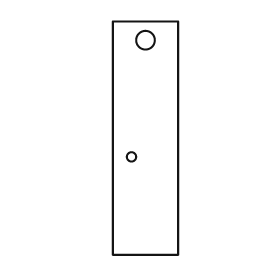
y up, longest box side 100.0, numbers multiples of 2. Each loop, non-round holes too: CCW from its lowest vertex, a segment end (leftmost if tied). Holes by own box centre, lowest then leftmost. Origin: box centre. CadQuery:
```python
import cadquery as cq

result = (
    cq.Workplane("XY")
    .moveTo(-14.0, -50.0)
    .lineTo(14.0, -50.0)
    .lineTo(14.0, 50.0)
    .lineTo(-14.0, 50.0)
    .close()
    .moveTo(-6.0, -8.0)
    .circle(2.0)
    .moveTo(0.0, 42.0)
    .circle(4.0)
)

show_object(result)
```